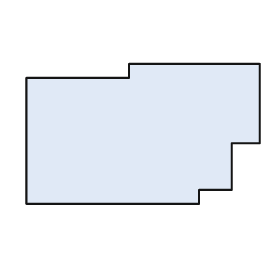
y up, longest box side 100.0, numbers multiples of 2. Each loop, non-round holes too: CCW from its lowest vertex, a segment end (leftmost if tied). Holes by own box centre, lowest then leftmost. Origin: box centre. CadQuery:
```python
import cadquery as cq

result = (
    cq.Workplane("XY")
    .moveTo(-50.0, -30.0)
    .lineTo(24.0, -30.0)
    .lineTo(24.0, -24.0)
    .lineTo(38.0, -24.0)
    .lineTo(38.0, -4.0)
    .lineTo(50.0, -4.0)
    .lineTo(50.0, 30.0)
    .lineTo(-6.0, 30.0)
    .lineTo(-6.0, 24.0)
    .lineTo(-50.0, 24.0)
    .close()
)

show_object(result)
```